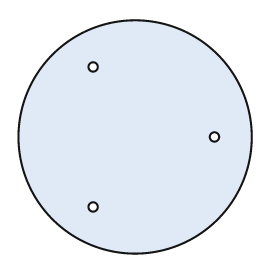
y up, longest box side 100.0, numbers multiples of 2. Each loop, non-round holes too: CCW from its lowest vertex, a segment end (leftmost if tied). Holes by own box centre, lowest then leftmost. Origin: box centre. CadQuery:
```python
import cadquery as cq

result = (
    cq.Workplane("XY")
    .moveTo(0.0, 0.0)
    .circle(50.0)
    .moveTo(-18.0, -30.0)
    .circle(2.0)
    .moveTo(34.0, 0.0)
    .circle(2.0)
    .moveTo(-18.0, 30.0)
    .circle(2.0)
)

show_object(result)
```